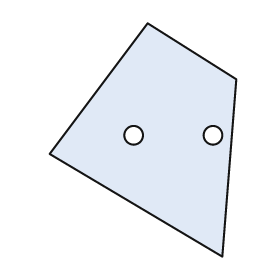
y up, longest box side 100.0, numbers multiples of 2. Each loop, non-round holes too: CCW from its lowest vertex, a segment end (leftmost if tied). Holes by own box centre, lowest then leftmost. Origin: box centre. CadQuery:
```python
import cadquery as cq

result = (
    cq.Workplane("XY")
    .moveTo(34.0, -50.0)
    .lineTo(40.0, 26.0)
    .lineTo(2.0, 50.0)
    .lineTo(-40.0, -6.0)
    .close()
    .moveTo(-4.0, 2.0)
    .circle(4.0)
    .moveTo(30.0, 2.0)
    .circle(4.0)
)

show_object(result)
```